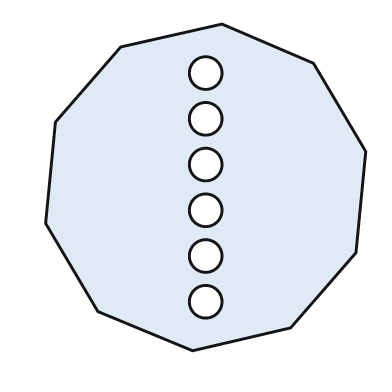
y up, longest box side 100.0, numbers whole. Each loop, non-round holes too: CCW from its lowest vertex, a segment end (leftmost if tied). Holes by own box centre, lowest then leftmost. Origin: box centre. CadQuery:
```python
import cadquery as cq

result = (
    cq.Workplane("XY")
    .moveTo(-4.0, -50.0)
    .lineTo(26.0, -43.0)
    .lineTo(46.0, -20.0)
    .lineTo(49.0, 11.0)
    .lineTo(33.0, 38.0)
    .lineTo(5.0, 50.0)
    .lineTo(-26.0, 43.0)
    .lineTo(-46.0, 20.0)
    .lineTo(-49.0, -11.0)
    .lineTo(-33.0, -38.0)
    .close()
    .moveTo(0.0, -35.0)
    .circle(5.0)
    .moveTo(0.0, -21.0)
    .circle(5.0)
    .moveTo(0.0, -7.0)
    .circle(5.0)
    .moveTo(0.0, 7.0)
    .circle(5.0)
    .moveTo(0.0, 21.0)
    .circle(5.0)
    .moveTo(0.0, 35.0)
    .circle(5.0)
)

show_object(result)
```